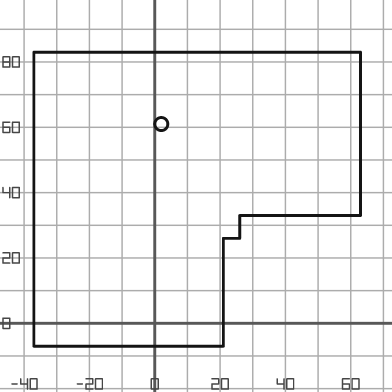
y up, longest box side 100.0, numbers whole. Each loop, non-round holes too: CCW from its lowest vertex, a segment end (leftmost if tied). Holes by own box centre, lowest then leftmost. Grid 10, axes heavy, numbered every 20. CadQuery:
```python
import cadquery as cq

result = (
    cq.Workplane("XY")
    .moveTo(-37.0, -7.0)
    .lineTo(21.0, -7.0)
    .lineTo(21.0, 26.0)
    .lineTo(26.0, 26.0)
    .lineTo(26.0, 33.0)
    .lineTo(63.0, 33.0)
    .lineTo(63.0, 83.0)
    .lineTo(-37.0, 83.0)
    .close()
    .moveTo(2.0, 61.0)
    .circle(2.0)
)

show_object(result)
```